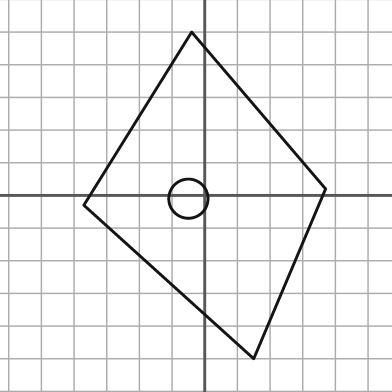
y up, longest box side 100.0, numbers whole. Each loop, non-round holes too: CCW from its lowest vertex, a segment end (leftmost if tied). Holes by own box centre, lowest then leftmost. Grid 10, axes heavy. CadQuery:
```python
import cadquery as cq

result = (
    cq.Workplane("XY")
    .moveTo(15.0, -50.0)
    .lineTo(37.0, 2.0)
    .lineTo(-4.0, 50.0)
    .lineTo(-37.0, -3.0)
    .close()
    .moveTo(-5.0, -1.0)
    .circle(6.0)
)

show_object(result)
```